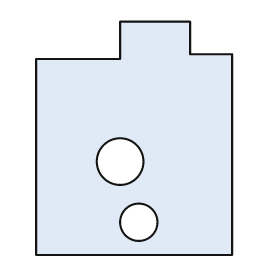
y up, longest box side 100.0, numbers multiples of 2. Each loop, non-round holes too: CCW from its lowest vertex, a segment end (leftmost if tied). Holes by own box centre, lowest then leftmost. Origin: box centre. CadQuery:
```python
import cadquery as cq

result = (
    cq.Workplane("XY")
    .moveTo(-42.0, -50.0)
    .lineTo(42.0, -50.0)
    .lineTo(42.0, 36.0)
    .lineTo(24.0, 36.0)
    .lineTo(24.0, 50.0)
    .lineTo(-6.0, 50.0)
    .lineTo(-6.0, 34.0)
    .lineTo(-42.0, 34.0)
    .close()
    .moveTo(2.0, -36.0)
    .circle(8.0)
    .moveTo(-6.0, -10.0)
    .circle(10.0)
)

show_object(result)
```